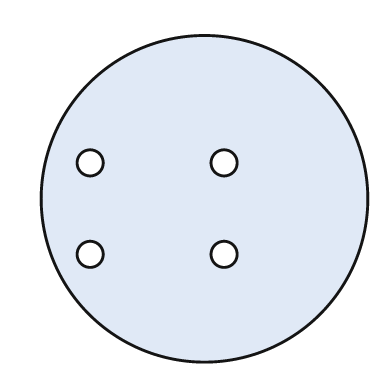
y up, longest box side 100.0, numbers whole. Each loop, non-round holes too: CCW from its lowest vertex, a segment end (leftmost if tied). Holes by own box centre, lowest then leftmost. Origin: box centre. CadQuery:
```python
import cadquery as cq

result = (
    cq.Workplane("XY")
    .moveTo(0.0, 0.0)
    .circle(50.0)
    .moveTo(-35.0, -17.0)
    .circle(4.0)
    .moveTo(6.0, -17.0)
    .circle(4.0)
    .moveTo(-35.0, 11.0)
    .circle(4.0)
    .moveTo(6.0, 11.0)
    .circle(4.0)
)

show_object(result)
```